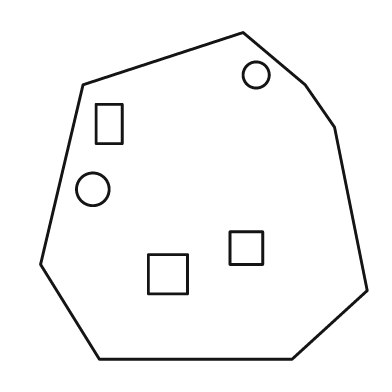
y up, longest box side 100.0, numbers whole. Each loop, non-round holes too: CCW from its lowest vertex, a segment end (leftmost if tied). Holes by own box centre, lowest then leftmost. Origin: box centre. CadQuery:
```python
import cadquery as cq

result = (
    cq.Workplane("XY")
    .moveTo(-32.0, -50.0)
    .lineTo(27.0, -50.0)
    .lineTo(50.0, -29.0)
    .lineTo(40.0, 21.0)
    .lineTo(31.0, 34.0)
    .lineTo(12.0, 50.0)
    .lineTo(-37.0, 34.0)
    .lineTo(-50.0, -21.0)
    .close()
    .moveTo(-17.0, -30.0)
    .lineTo(-5.0, -30.0)
    .lineTo(-5.0, -18.0)
    .lineTo(-17.0, -18.0)
    .close()
    .moveTo(8.0, -21.0)
    .lineTo(18.0, -21.0)
    .lineTo(18.0, -11.0)
    .lineTo(8.0, -11.0)
    .close()
    .moveTo(-34.0, 2.0)
    .circle(5.0)
    .moveTo(-33.0, 16.0)
    .lineTo(-25.0, 16.0)
    .lineTo(-25.0, 28.0)
    .lineTo(-33.0, 28.0)
    .close()
    .moveTo(16.0, 37.0)
    .circle(4.0)
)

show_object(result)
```